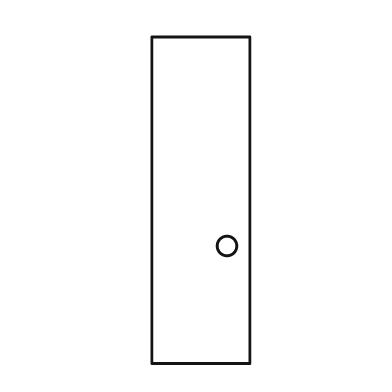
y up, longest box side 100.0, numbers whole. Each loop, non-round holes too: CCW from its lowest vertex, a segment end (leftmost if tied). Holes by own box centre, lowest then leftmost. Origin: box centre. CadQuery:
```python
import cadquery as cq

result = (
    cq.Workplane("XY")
    .moveTo(-15.0, -50.0)
    .lineTo(15.0, -50.0)
    .lineTo(15.0, 50.0)
    .lineTo(-15.0, 50.0)
    .close()
    .moveTo(8.0, -14.0)
    .circle(3.0)
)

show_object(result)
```